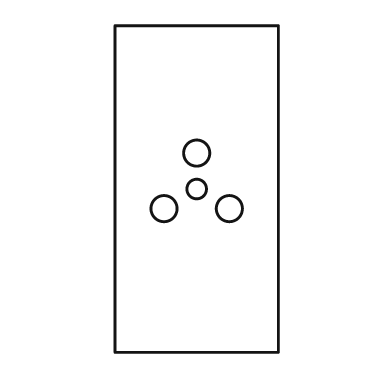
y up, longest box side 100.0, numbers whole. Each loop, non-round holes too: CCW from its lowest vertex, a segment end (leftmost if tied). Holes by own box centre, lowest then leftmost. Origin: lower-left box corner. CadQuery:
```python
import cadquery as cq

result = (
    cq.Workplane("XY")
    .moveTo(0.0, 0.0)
    .lineTo(50.0, 0.0)
    .lineTo(50.0, 100.0)
    .lineTo(0.0, 100.0)
    .close()
    .moveTo(15.0, 44.0)
    .circle(4.0)
    .moveTo(35.0, 44.0)
    .circle(4.0)
    .moveTo(25.0, 50.0)
    .circle(3.0)
    .moveTo(25.0, 61.0)
    .circle(4.0)
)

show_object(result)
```